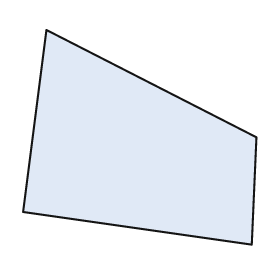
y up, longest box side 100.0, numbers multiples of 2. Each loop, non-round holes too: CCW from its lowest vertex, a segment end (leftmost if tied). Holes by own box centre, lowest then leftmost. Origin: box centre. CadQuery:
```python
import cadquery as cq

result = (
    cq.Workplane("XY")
    .moveTo(48.0, -46.0)
    .lineTo(50.0, 0.0)
    .lineTo(-40.0, 46.0)
    .lineTo(-50.0, -32.0)
    .close()
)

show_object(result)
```